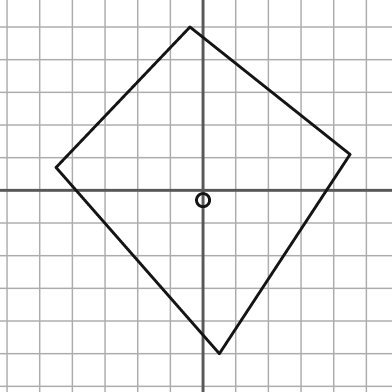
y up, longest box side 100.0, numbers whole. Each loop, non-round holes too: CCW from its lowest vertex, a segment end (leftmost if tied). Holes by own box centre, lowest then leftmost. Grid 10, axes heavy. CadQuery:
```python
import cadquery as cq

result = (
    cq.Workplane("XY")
    .moveTo(5.0, -50.0)
    .lineTo(45.0, 11.0)
    .lineTo(-4.0, 50.0)
    .lineTo(-45.0, 7.0)
    .close()
    .moveTo(0.0, -3.0)
    .circle(2.0)
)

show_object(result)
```